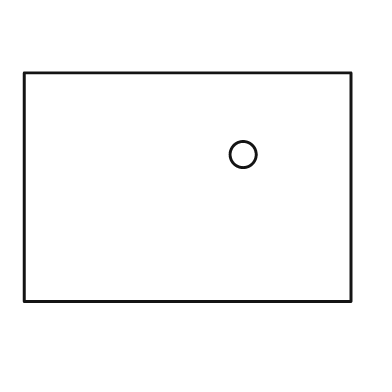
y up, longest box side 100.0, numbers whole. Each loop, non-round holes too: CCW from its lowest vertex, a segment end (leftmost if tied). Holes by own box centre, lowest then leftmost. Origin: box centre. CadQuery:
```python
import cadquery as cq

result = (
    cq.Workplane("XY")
    .moveTo(-50.0, -35.0)
    .lineTo(50.0, -35.0)
    .lineTo(50.0, 35.0)
    .lineTo(-50.0, 35.0)
    .close()
    .moveTo(17.0, 10.0)
    .circle(4.0)
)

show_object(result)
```